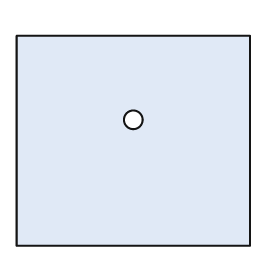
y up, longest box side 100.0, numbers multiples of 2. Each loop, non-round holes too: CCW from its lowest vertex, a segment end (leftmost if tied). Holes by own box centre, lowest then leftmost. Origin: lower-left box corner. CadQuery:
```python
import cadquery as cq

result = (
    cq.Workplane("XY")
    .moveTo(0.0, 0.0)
    .lineTo(100.0, 0.0)
    .lineTo(100.0, 90.0)
    .lineTo(0.0, 90.0)
    .close()
    .moveTo(50.0, 54.0)
    .circle(4.0)
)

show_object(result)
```